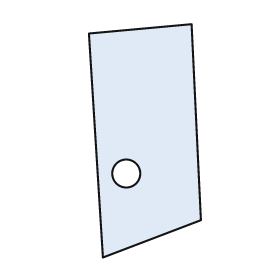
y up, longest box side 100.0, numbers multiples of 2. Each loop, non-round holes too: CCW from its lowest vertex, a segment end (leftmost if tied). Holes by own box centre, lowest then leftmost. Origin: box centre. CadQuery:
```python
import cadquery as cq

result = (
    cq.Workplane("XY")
    .moveTo(-18.0, -50.0)
    .lineTo(24.0, -34.0)
    .lineTo(20.0, 50.0)
    .lineTo(-24.0, 46.0)
    .close()
    .moveTo(-8.0, -14.0)
    .circle(6.0)
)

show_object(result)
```